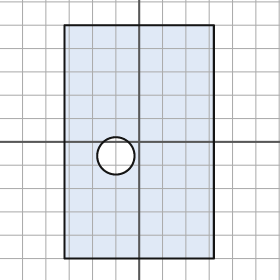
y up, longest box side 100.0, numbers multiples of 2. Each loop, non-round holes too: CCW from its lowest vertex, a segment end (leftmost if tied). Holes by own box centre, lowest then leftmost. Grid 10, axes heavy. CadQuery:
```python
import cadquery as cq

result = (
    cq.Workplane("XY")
    .moveTo(-32.0, -50.0)
    .lineTo(32.0, -50.0)
    .lineTo(32.0, 50.0)
    .lineTo(-32.0, 50.0)
    .close()
    .moveTo(-10.0, -6.0)
    .circle(8.0)
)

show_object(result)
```